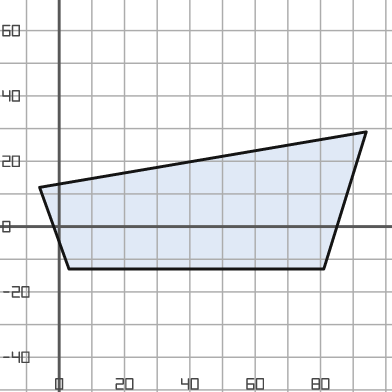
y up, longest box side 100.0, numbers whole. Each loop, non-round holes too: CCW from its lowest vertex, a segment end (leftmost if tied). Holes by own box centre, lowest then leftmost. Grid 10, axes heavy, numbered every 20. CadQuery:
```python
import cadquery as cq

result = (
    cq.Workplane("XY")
    .moveTo(3.0, -13.0)
    .lineTo(81.0, -13.0)
    .lineTo(94.0, 29.0)
    .lineTo(-6.0, 12.0)
    .close()
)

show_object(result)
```